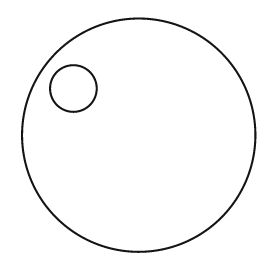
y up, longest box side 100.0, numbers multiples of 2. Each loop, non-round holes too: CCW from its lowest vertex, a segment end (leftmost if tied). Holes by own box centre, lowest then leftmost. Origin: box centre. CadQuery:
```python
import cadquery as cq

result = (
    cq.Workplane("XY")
    .moveTo(0.0, 0.0)
    .circle(50.0)
    .moveTo(-28.0, 20.0)
    .circle(10.0)
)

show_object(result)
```